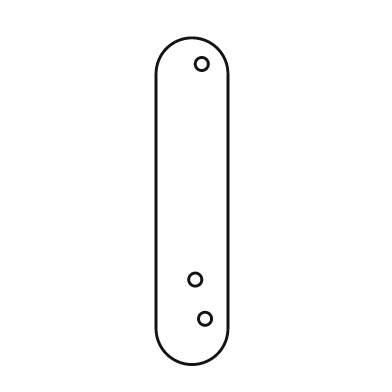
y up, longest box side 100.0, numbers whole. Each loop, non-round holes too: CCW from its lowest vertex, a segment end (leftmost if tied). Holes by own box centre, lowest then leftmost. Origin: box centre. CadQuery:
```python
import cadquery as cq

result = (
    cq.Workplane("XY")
    .moveTo(-11.0, -39.0)
    .threePointArc((0.0, -50.0), (11.0, -39.0))
    .lineTo(11.0, 39.0)
    .threePointArc((0.0, 50.0), (-11.0, 39.0))
    .close()
    .moveTo(4.0, -36.0)
    .circle(2.0)
    .moveTo(1.0, -24.0)
    .circle(2.0)
    .moveTo(3.0, 42.0)
    .circle(2.0)
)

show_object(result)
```